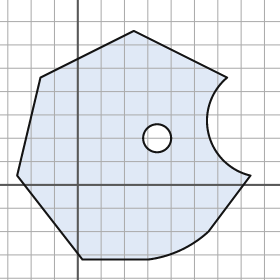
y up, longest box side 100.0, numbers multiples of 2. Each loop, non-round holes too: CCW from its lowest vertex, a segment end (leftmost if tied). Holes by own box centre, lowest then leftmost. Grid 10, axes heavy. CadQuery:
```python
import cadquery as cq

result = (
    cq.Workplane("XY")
    .moveTo(2.0, -32.0)
    .lineTo(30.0, -32.0)
    .threePointArc((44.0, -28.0), (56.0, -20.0))
    .lineTo(74.0, 4.0)
    .threePointArc((56.0, 22.0), (64.0, 46.0))
    .lineTo(24.0, 66.0)
    .lineTo(-16.0, 46.0)
    .lineTo(-26.0, 4.0)
    .close()
    .moveTo(34.0, 20.0)
    .circle(6.0)
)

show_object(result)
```